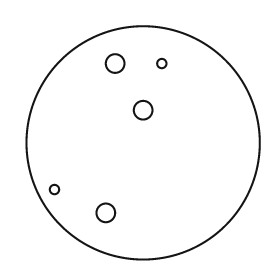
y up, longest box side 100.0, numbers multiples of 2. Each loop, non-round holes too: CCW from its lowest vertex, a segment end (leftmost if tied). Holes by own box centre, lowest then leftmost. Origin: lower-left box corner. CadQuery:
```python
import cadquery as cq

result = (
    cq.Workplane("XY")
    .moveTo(50.0, 50.0)
    .circle(50.0)
    .moveTo(34.0, 20.0)
    .circle(4.0)
    .moveTo(12.0, 30.0)
    .circle(2.0)
    .moveTo(50.0, 64.0)
    .circle(4.0)
    .moveTo(38.0, 84.0)
    .circle(4.0)
    .moveTo(58.0, 84.0)
    .circle(2.0)
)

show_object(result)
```